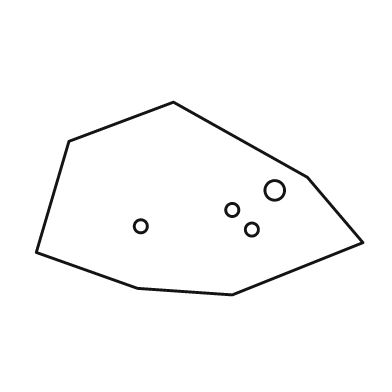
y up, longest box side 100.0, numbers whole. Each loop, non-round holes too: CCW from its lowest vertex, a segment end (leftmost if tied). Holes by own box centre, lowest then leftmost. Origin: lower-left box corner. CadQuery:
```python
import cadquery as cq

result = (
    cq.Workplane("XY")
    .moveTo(60.0, 0.0)
    .lineTo(100.0, 16.0)
    .lineTo(83.0, 36.0)
    .lineTo(42.0, 59.0)
    .lineTo(10.0, 47.0)
    .lineTo(0.0, 13.0)
    .lineTo(31.0, 2.0)
    .close()
    .moveTo(66.0, 20.0)
    .circle(2.0)
    .moveTo(32.0, 21.0)
    .circle(2.0)
    .moveTo(60.0, 26.0)
    .circle(2.0)
    .moveTo(73.0, 32.0)
    .circle(3.0)
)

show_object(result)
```